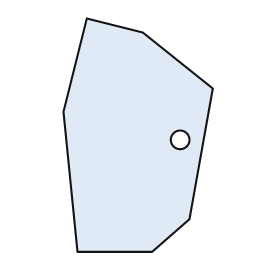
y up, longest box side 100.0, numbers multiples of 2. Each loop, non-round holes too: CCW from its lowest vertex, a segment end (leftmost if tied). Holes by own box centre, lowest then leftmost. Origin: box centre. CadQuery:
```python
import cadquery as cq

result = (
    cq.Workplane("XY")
    .moveTo(-26.0, -50.0)
    .lineTo(6.0, -50.0)
    .lineTo(22.0, -36.0)
    .lineTo(32.0, 20.0)
    .lineTo(2.0, 44.0)
    .lineTo(-22.0, 50.0)
    .lineTo(-32.0, 10.0)
    .close()
    .moveTo(18.0, -2.0)
    .circle(4.0)
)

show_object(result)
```